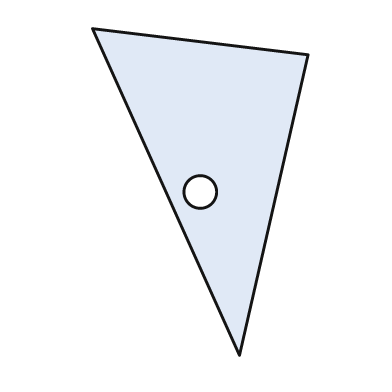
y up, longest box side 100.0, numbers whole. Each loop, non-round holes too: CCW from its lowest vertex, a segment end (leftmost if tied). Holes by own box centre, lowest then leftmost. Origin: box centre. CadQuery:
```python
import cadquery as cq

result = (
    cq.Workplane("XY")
    .moveTo(12.0, -50.0)
    .lineTo(33.0, 42.0)
    .lineTo(-33.0, 50.0)
    .close()
    .moveTo(0.0, 0.0)
    .circle(5.0)
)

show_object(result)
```